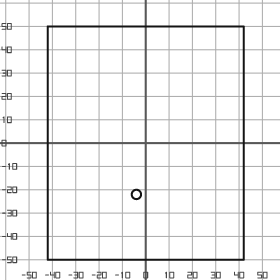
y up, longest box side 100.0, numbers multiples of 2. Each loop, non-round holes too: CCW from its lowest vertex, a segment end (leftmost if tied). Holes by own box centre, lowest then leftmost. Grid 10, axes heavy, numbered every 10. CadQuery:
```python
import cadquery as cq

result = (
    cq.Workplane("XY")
    .moveTo(-42.0, -50.0)
    .lineTo(42.0, -50.0)
    .lineTo(42.0, 50.0)
    .lineTo(-42.0, 50.0)
    .close()
    .moveTo(-4.0, -22.0)
    .circle(2.0)
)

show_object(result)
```